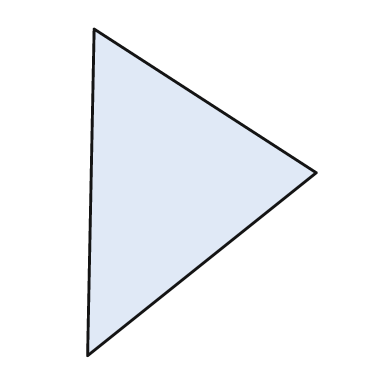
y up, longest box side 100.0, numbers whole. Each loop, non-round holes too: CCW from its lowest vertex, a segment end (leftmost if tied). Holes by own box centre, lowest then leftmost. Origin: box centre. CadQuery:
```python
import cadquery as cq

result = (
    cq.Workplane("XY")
    .moveTo(-35.0, -50.0)
    .lineTo(35.0, 6.0)
    .lineTo(-33.0, 50.0)
    .close()
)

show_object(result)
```